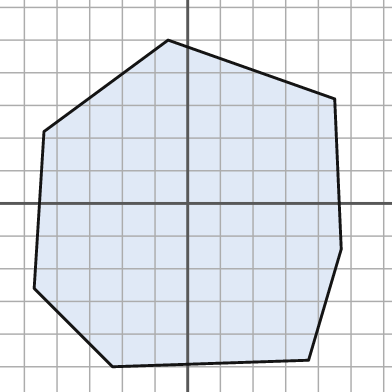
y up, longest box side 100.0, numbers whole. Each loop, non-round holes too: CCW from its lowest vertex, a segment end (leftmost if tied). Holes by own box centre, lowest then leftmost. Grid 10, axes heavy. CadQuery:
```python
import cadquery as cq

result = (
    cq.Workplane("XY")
    .moveTo(-23.0, -50.0)
    .lineTo(37.0, -48.0)
    .lineTo(47.0, -14.0)
    .lineTo(45.0, 32.0)
    .lineTo(-6.0, 50.0)
    .lineTo(-44.0, 22.0)
    .lineTo(-47.0, -26.0)
    .close()
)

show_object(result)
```